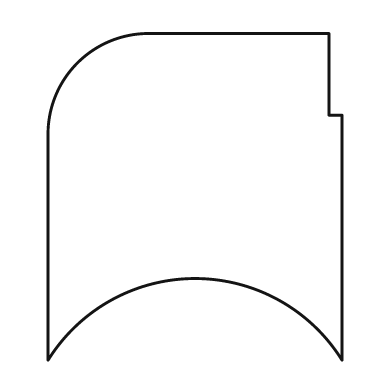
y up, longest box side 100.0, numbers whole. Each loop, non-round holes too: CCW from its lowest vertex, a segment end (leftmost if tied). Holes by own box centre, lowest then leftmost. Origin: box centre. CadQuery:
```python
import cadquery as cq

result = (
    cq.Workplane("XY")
    .moveTo(-45.0, -50.0)
    .threePointArc((0.0, -25.0), (45.0, -50.0))
    .lineTo(45.0, 25.0)
    .lineTo(41.0, 25.0)
    .lineTo(41.0, 50.0)
    .lineTo(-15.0, 50.0)
    .threePointArc((-36.0, 41.0), (-45.0, 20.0))
    .close()
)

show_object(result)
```